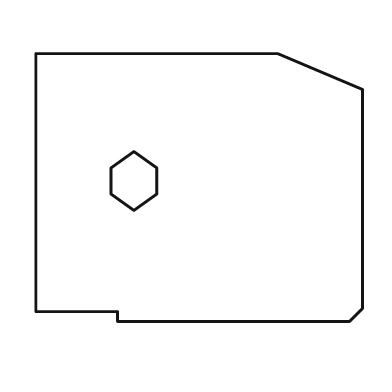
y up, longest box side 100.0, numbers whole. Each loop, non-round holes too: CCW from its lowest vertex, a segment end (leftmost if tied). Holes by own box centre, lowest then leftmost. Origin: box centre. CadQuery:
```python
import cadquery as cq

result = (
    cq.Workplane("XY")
    .moveTo(-25.0, -41.0)
    .lineTo(46.0, -41.0)
    .lineTo(50.0, -37.0)
    .lineTo(50.0, 30.0)
    .lineTo(24.0, 41.0)
    .lineTo(-50.0, 41.0)
    .lineTo(-50.0, -38.0)
    .lineTo(-25.0, -38.0)
    .close()
    .moveTo(-20.0, -7.0)
    .lineTo(-13.0, -2.0)
    .lineTo(-13.0, 6.0)
    .lineTo(-20.0, 11.0)
    .lineTo(-27.0, 6.0)
    .lineTo(-27.0, -2.0)
    .close()
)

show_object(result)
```